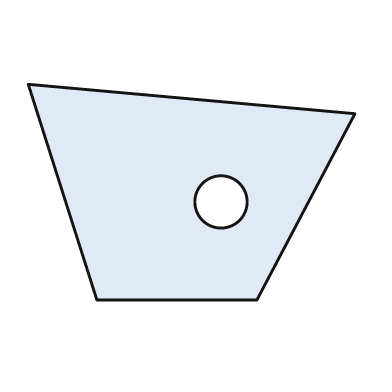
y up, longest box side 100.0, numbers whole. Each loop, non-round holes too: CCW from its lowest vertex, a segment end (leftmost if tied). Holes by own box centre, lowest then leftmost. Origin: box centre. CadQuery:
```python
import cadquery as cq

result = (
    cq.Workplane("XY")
    .moveTo(-29.0, -33.0)
    .lineTo(20.0, -33.0)
    .lineTo(50.0, 24.0)
    .lineTo(-50.0, 33.0)
    .close()
    .moveTo(9.0, -3.0)
    .circle(8.0)
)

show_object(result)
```